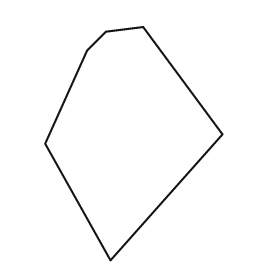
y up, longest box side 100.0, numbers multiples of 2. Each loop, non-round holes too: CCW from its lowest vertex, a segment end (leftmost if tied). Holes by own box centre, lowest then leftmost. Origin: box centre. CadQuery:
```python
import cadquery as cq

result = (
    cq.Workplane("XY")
    .moveTo(-10.0, -50.0)
    .lineTo(38.0, 4.0)
    .lineTo(4.0, 50.0)
    .lineTo(-12.0, 48.0)
    .lineTo(-20.0, 40.0)
    .lineTo(-38.0, 0.0)
    .close()
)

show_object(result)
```